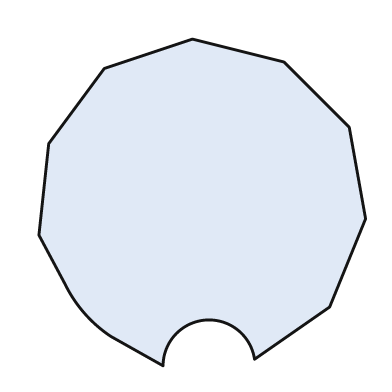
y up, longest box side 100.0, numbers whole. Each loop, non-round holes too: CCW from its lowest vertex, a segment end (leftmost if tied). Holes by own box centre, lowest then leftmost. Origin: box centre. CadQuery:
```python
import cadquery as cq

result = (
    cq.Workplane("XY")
    .moveTo(-12.0, -50.0)
    .threePointArc((1.0, -36.0), (16.0, -48.0))
    .lineTo(39.0, -32.0)
    .lineTo(50.0, -5.0)
    .lineTo(45.0, 23.0)
    .lineTo(25.0, 43.0)
    .lineTo(-3.0, 50.0)
    .lineTo(-30.0, 41.0)
    .lineTo(-47.0, 18.0)
    .lineTo(-50.0, -10.0)
    .lineTo(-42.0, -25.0)
    .threePointArc((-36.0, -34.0), (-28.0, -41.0))
    .close()
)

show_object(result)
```